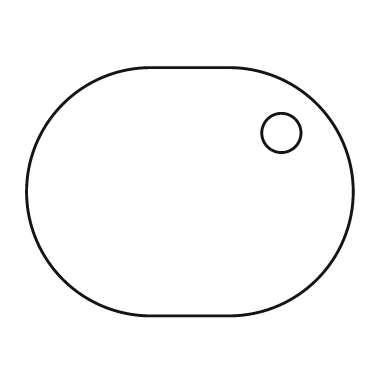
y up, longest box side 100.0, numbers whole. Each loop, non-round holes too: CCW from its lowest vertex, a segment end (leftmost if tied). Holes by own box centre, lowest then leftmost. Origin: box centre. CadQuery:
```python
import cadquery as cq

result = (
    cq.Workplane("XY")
    .moveTo(-12.0, -38.0)
    .lineTo(12.0, -38.0)
    .threePointArc((50.0, 0.0), (12.0, 38.0))
    .lineTo(-12.0, 38.0)
    .threePointArc((-50.0, 0.0), (-12.0, -38.0))
    .close()
    .moveTo(28.0, 18.0)
    .circle(6.0)
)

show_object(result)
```